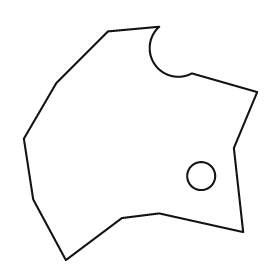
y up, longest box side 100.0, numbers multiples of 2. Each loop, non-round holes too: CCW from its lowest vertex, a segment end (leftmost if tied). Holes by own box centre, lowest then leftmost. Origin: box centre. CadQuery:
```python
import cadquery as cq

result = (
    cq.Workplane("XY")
    .moveTo(-32.0, -50.0)
    .lineTo(-8.0, -32.0)
    .lineTo(8.0, -30.0)
    .lineTo(44.0, -38.0)
    .lineTo(40.0, -2.0)
    .lineTo(50.0, 22.0)
    .lineTo(22.0, 30.0)
    .threePointArc((6.0, 34.0), (8.0, 50.0))
    .lineTo(-14.0, 48.0)
    .lineTo(-36.0, 26.0)
    .lineTo(-50.0, 2.0)
    .lineTo(-46.0, -24.0)
    .close()
    .moveTo(26.0, -14.0)
    .circle(6.0)
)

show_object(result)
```